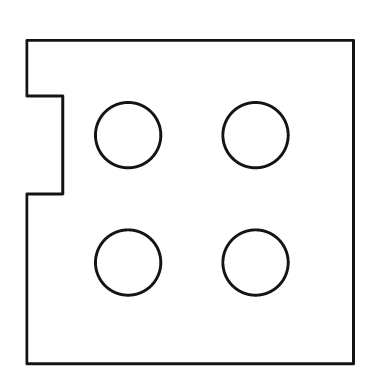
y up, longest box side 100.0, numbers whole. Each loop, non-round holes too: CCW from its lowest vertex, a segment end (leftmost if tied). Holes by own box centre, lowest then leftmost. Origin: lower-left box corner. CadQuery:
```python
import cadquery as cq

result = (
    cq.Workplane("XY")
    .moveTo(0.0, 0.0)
    .lineTo(100.0, 0.0)
    .lineTo(100.0, 99.0)
    .lineTo(0.0, 99.0)
    .lineTo(0.0, 82.0)
    .lineTo(11.0, 82.0)
    .lineTo(11.0, 52.0)
    .lineTo(0.0, 52.0)
    .close()
    .moveTo(31.0, 31.0)
    .circle(10.0)
    .moveTo(70.0, 31.0)
    .circle(10.0)
    .moveTo(31.0, 70.0)
    .circle(10.0)
    .moveTo(70.0, 70.0)
    .circle(10.0)
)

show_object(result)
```